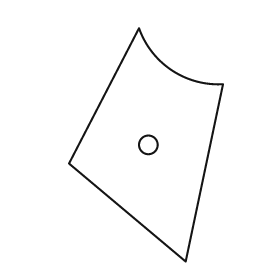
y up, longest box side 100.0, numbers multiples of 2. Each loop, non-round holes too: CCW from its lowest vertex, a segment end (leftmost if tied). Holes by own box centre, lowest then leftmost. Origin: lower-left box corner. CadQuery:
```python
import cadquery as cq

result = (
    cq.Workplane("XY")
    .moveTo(50.0, 0.0)
    .lineTo(66.0, 76.0)
    .threePointArc((44.0, 82.0), (30.0, 100.0))
    .lineTo(0.0, 42.0)
    .close()
    .moveTo(34.0, 50.0)
    .circle(4.0)
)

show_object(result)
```